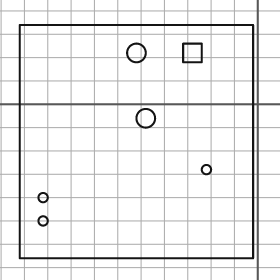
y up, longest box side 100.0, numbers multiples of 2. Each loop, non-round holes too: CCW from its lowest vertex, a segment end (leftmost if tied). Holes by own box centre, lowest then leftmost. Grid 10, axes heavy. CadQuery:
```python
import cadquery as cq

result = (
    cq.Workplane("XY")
    .moveTo(-102.0, -66.0)
    .lineTo(-2.0, -66.0)
    .lineTo(-2.0, 34.0)
    .lineTo(-102.0, 34.0)
    .close()
    .moveTo(-92.0, -50.0)
    .circle(2.0)
    .moveTo(-92.0, -40.0)
    .circle(2.0)
    .moveTo(-22.0, -28.0)
    .circle(2.0)
    .moveTo(-48.0, -6.0)
    .circle(4.0)
    .moveTo(-52.0, 22.0)
    .circle(4.0)
    .moveTo(-32.0, 18.0)
    .lineTo(-24.0, 18.0)
    .lineTo(-24.0, 26.0)
    .lineTo(-32.0, 26.0)
    .close()
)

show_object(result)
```